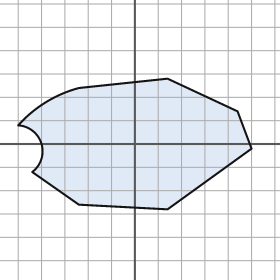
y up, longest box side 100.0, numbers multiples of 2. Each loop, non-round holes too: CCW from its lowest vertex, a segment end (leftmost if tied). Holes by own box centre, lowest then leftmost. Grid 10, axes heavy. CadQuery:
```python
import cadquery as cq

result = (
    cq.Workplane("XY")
    .moveTo(14.0, -28.0)
    .lineTo(50.0, -2.0)
    .lineTo(44.0, 14.0)
    .lineTo(14.0, 28.0)
    .lineTo(-24.0, 24.0)
    .threePointArc((-38.0, 18.0), (-50.0, 8.0))
    .threePointArc((-40.0, 0.0), (-44.0, -12.0))
    .lineTo(-24.0, -26.0)
    .close()
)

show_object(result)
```